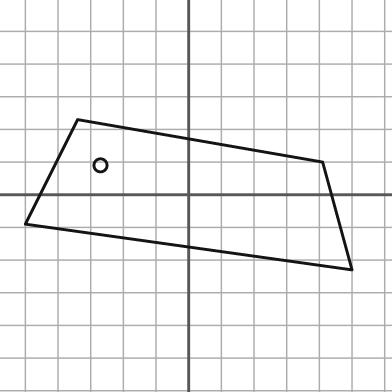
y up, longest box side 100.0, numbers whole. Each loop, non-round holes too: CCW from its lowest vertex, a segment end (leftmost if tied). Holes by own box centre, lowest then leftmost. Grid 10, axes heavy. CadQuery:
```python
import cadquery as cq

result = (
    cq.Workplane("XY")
    .moveTo(50.0, -23.0)
    .lineTo(41.0, 10.0)
    .lineTo(-34.0, 23.0)
    .lineTo(-50.0, -9.0)
    .close()
    .moveTo(-27.0, 9.0)
    .circle(2.0)
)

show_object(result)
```